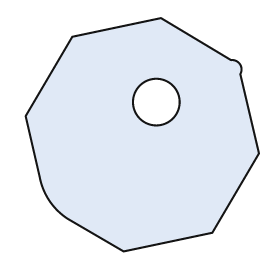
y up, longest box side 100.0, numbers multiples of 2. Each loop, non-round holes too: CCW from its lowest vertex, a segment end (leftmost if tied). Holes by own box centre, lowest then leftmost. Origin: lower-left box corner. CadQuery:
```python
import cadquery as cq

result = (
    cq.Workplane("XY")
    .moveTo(42.0, 0.0)
    .lineTo(80.0, 8.0)
    .lineTo(100.0, 42.0)
    .lineTo(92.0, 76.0)
    .threePointArc((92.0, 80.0), (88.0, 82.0))
    .lineTo(58.0, 100.0)
    .lineTo(20.0, 92.0)
    .lineTo(0.0, 58.0)
    .lineTo(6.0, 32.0)
    .threePointArc((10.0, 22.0), (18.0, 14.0))
    .close()
    .moveTo(56.0, 64.0)
    .circle(10.0)
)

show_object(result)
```